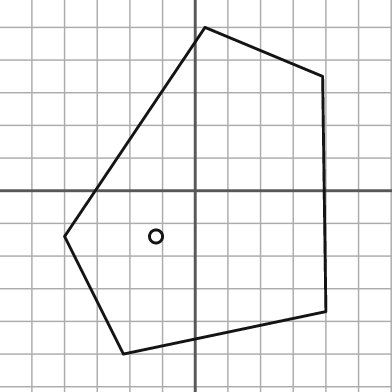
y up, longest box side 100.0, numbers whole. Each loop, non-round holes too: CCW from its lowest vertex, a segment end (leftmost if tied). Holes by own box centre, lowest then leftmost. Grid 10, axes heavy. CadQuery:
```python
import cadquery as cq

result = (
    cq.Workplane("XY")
    .moveTo(-22.0, -50.0)
    .lineTo(40.0, -37.0)
    .lineTo(39.0, 35.0)
    .lineTo(3.0, 50.0)
    .lineTo(-40.0, -14.0)
    .close()
    .moveTo(-12.0, -14.0)
    .circle(2.0)
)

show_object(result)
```